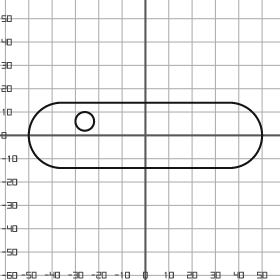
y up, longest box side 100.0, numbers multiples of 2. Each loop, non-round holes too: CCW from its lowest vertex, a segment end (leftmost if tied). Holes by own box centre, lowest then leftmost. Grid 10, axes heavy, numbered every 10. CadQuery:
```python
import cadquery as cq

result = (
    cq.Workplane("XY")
    .moveTo(-36.0, -14.0)
    .lineTo(36.0, -14.0)
    .threePointArc((50.0, 0.0), (36.0, 14.0))
    .lineTo(-36.0, 14.0)
    .threePointArc((-50.0, 0.0), (-36.0, -14.0))
    .close()
    .moveTo(-26.0, 6.0)
    .circle(4.0)
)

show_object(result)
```